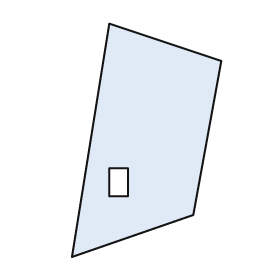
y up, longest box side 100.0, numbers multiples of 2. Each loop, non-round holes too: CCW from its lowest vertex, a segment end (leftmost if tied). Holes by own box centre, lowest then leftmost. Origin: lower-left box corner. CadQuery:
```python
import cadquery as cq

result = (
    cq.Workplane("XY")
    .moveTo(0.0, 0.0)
    .lineTo(52.0, 18.0)
    .lineTo(64.0, 84.0)
    .lineTo(16.0, 100.0)
    .close()
    .moveTo(16.0, 26.0)
    .lineTo(24.0, 26.0)
    .lineTo(24.0, 38.0)
    .lineTo(16.0, 38.0)
    .close()
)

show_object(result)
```